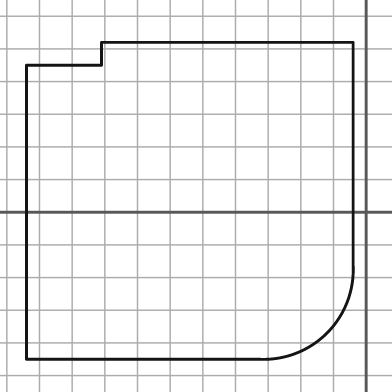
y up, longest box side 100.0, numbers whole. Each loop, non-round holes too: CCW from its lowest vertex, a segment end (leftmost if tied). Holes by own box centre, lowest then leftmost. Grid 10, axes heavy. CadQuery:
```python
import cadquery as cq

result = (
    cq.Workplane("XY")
    .moveTo(-104.0, -45.0)
    .lineTo(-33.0, -45.0)
    .threePointArc((-12.0, -37.0), (-4.0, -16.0))
    .lineTo(-4.0, 52.0)
    .lineTo(-81.0, 52.0)
    .lineTo(-81.0, 45.0)
    .lineTo(-104.0, 45.0)
    .close()
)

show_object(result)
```